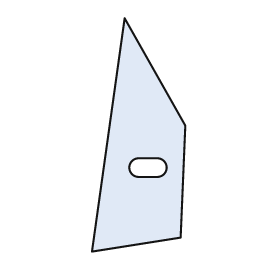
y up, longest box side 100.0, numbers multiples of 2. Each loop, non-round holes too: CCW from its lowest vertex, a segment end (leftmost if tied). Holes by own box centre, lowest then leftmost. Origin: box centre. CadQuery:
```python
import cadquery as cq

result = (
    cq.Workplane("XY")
    .moveTo(-20.0, -50.0)
    .lineTo(18.0, -44.0)
    .lineTo(20.0, 4.0)
    .lineTo(-6.0, 50.0)
    .close()
    .moveTo(0.0, -18.0)
    .lineTo(8.0, -18.0)
    .threePointArc((12.0, -14.0), (8.0, -10.0))
    .lineTo(0.0, -10.0)
    .threePointArc((-4.0, -14.0), (0.0, -18.0))
    .close()
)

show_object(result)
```